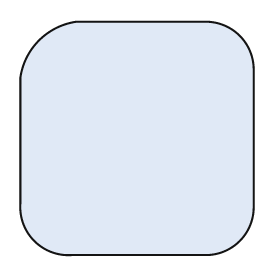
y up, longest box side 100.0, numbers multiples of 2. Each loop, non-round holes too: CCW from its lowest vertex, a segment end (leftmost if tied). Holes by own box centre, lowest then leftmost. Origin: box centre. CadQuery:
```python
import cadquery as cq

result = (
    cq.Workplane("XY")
    .moveTo(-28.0, -50.0)
    .lineTo(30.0, -50.0)
    .threePointArc((44.0, -44.0), (50.0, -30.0))
    .lineTo(50.0, 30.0)
    .threePointArc((44.0, 44.0), (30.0, 50.0))
    .lineTo(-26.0, 50.0)
    .threePointArc((-42.0, 42.0), (-50.0, 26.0))
    .lineTo(-50.0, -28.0)
    .threePointArc((-44.0, -44.0), (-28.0, -50.0))
    .close()
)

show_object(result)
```